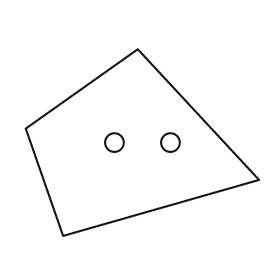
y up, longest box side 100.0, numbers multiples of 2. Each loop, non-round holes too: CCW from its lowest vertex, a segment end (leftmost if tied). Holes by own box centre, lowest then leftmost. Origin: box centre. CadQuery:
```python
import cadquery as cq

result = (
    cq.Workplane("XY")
    .moveTo(-34.0, -40.0)
    .lineTo(50.0, -16.0)
    .lineTo(-2.0, 40.0)
    .lineTo(-50.0, 6.0)
    .close()
    .moveTo(-12.0, 0.0)
    .circle(4.0)
    .moveTo(12.0, 0.0)
    .circle(4.0)
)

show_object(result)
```